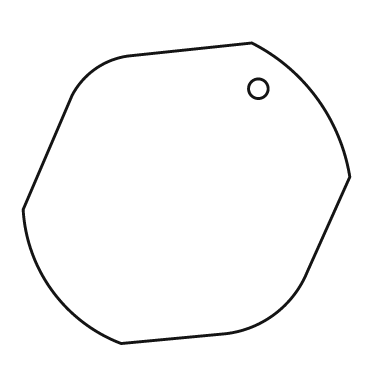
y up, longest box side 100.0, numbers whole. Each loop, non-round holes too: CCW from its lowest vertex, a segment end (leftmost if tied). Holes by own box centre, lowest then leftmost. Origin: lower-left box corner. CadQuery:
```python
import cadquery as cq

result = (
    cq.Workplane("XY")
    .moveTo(30.0, 0.0)
    .lineTo(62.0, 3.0)
    .threePointArc((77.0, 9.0), (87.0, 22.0))
    .lineTo(100.0, 51.0)
    .threePointArc((90.0, 75.0), (70.0, 92.0))
    .lineTo(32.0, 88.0)
    .threePointArc((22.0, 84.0), (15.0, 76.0))
    .lineTo(0.0, 41.0)
    .threePointArc((9.0, 16.0), (30.0, 0.0))
    .close()
    .moveTo(72.0, 78.0)
    .circle(3.0)
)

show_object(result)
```